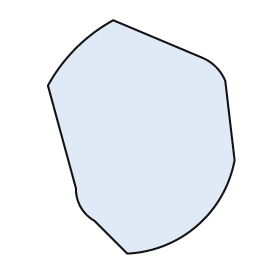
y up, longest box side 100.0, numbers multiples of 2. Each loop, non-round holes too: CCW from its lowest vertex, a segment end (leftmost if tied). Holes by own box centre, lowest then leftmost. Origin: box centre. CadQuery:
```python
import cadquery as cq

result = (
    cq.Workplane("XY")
    .moveTo(-6.0, -50.0)
    .threePointArc((24.0, -38.0), (40.0, -10.0))
    .lineTo(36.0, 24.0)
    .threePointArc((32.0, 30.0), (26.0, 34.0))
    .lineTo(-12.0, 50.0)
    .threePointArc((-28.0, 38.0), (-40.0, 22.0))
    .lineTo(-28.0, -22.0)
    .threePointArc((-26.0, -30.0), (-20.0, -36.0))
    .close()
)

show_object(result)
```